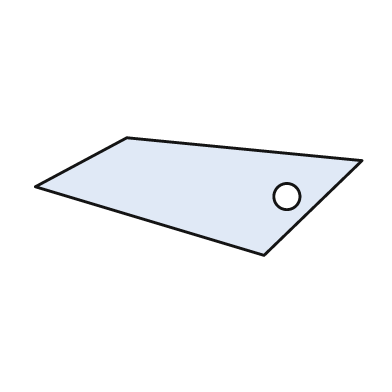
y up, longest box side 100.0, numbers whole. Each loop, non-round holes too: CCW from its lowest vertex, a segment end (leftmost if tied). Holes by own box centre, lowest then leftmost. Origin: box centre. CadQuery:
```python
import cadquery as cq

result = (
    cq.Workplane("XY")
    .moveTo(20.0, -18.0)
    .lineTo(50.0, 11.0)
    .lineTo(-22.0, 18.0)
    .lineTo(-50.0, 3.0)
    .close()
    .moveTo(27.0, 0.0)
    .circle(4.0)
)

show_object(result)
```